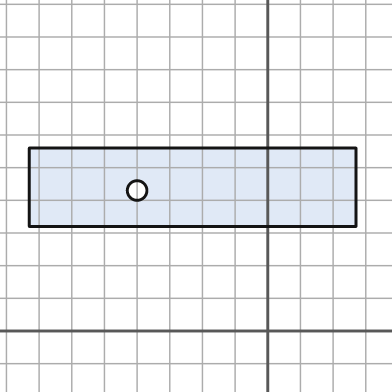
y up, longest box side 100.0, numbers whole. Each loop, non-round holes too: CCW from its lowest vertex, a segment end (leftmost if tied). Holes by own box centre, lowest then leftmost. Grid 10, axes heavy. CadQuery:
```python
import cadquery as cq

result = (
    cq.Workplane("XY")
    .moveTo(-73.0, 32.0)
    .lineTo(27.0, 32.0)
    .lineTo(27.0, 56.0)
    .lineTo(-73.0, 56.0)
    .close()
    .moveTo(-40.0, 43.0)
    .circle(3.0)
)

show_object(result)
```